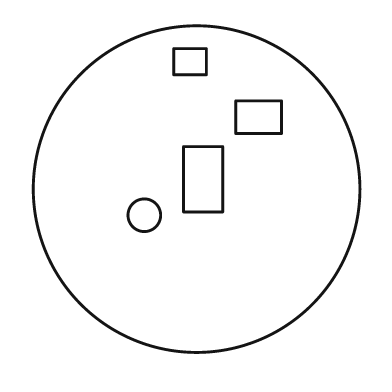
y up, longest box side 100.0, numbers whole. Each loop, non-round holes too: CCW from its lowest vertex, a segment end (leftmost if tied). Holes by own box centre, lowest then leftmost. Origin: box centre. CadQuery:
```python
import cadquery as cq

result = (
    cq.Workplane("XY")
    .moveTo(0.0, 0.0)
    .circle(50.0)
    .moveTo(-16.0, -8.0)
    .circle(5.0)
    .moveTo(-4.0, -7.0)
    .lineTo(8.0, -7.0)
    .lineTo(8.0, 13.0)
    .lineTo(-4.0, 13.0)
    .close()
    .moveTo(12.0, 17.0)
    .lineTo(26.0, 17.0)
    .lineTo(26.0, 27.0)
    .lineTo(12.0, 27.0)
    .close()
    .moveTo(-7.0, 35.0)
    .lineTo(3.0, 35.0)
    .lineTo(3.0, 43.0)
    .lineTo(-7.0, 43.0)
    .close()
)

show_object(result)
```